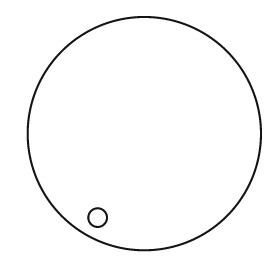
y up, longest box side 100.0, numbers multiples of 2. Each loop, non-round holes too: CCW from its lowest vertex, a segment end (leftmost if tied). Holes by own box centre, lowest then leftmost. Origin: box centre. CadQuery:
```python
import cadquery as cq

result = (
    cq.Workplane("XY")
    .moveTo(0.0, 0.0)
    .circle(50.0)
    .moveTo(-20.0, -36.0)
    .circle(4.0)
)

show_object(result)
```